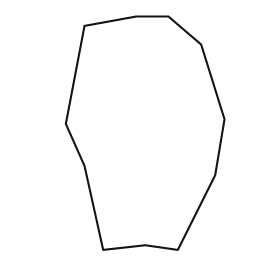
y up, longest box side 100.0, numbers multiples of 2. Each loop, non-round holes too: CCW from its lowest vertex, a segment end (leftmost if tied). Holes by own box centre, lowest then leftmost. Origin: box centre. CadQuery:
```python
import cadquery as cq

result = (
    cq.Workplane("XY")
    .moveTo(-18.0, -50.0)
    .lineTo(0.0, -48.0)
    .lineTo(14.0, -50.0)
    .lineTo(30.0, -18.0)
    .lineTo(34.0, 6.0)
    .lineTo(24.0, 38.0)
    .lineTo(10.0, 50.0)
    .lineTo(-4.0, 50.0)
    .lineTo(-26.0, 46.0)
    .lineTo(-34.0, 4.0)
    .lineTo(-26.0, -14.0)
    .close()
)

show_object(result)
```